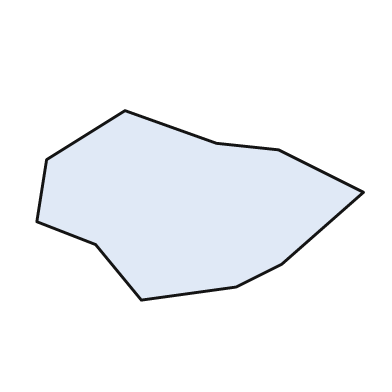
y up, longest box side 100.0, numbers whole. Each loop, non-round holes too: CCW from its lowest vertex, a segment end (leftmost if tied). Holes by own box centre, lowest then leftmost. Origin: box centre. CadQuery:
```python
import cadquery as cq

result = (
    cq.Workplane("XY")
    .moveTo(-18.0, -29.0)
    .lineTo(11.0, -25.0)
    .lineTo(25.0, -18.0)
    .lineTo(50.0, 4.0)
    .lineTo(24.0, 17.0)
    .lineTo(5.0, 19.0)
    .lineTo(-23.0, 29.0)
    .lineTo(-47.0, 14.0)
    .lineTo(-50.0, -5.0)
    .lineTo(-32.0, -12.0)
    .close()
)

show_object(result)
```